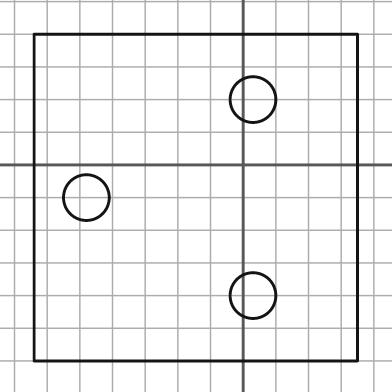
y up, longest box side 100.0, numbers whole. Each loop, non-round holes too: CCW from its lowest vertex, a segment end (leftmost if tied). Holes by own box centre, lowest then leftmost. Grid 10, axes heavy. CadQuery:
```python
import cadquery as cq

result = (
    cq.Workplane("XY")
    .moveTo(-64.0, -60.0)
    .lineTo(35.0, -60.0)
    .lineTo(35.0, 40.0)
    .lineTo(-64.0, 40.0)
    .close()
    .moveTo(3.0, -40.0)
    .circle(7.0)
    .moveTo(-48.0, -10.0)
    .circle(7.0)
    .moveTo(3.0, 20.0)
    .circle(7.0)
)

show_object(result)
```